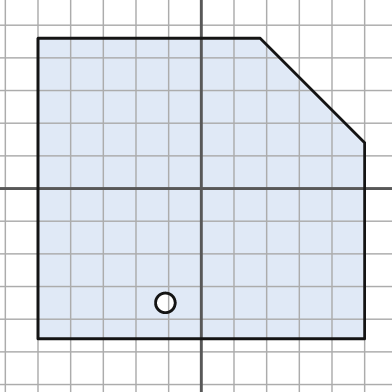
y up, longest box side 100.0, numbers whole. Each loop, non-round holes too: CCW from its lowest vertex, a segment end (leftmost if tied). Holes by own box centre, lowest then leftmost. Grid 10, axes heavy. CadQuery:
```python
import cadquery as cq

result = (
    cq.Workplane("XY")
    .moveTo(-50.0, -46.0)
    .lineTo(50.0, -46.0)
    .lineTo(50.0, 14.0)
    .lineTo(18.0, 46.0)
    .lineTo(-50.0, 46.0)
    .close()
    .moveTo(-11.0, -35.0)
    .circle(3.0)
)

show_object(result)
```